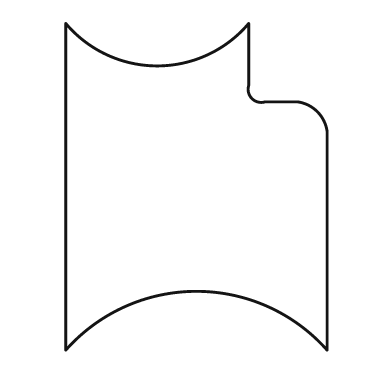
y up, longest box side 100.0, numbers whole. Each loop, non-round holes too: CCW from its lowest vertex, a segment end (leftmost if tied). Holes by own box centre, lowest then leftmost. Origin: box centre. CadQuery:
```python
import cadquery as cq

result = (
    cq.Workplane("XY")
    .moveTo(-40.0, -50.0)
    .threePointArc((0.0, -32.0), (40.0, -50.0))
    .lineTo(40.0, 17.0)
    .threePointArc((37.0, 23.0), (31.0, 26.0))
    .lineTo(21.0, 26.0)
    .threePointArc((17.0, 27.0), (16.0, 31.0))
    .lineTo(16.0, 50.0)
    .threePointArc((-12.0, 37.0), (-40.0, 50.0))
    .close()
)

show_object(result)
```